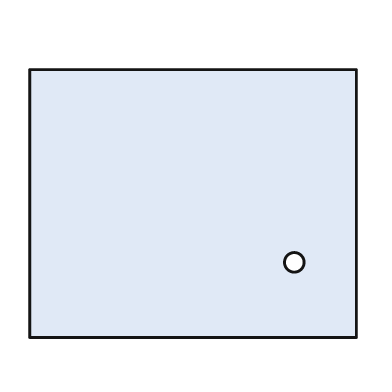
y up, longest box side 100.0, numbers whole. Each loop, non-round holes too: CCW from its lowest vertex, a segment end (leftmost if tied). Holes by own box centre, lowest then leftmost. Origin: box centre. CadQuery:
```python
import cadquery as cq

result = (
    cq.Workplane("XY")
    .moveTo(-50.0, -41.0)
    .lineTo(50.0, -41.0)
    .lineTo(50.0, 41.0)
    .lineTo(-50.0, 41.0)
    .close()
    .moveTo(31.0, -18.0)
    .circle(3.0)
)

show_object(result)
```